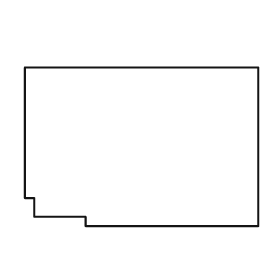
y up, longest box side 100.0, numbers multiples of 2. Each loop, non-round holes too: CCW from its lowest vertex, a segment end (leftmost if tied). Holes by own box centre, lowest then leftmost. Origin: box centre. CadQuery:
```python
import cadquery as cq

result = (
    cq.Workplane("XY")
    .moveTo(-24.0, -34.0)
    .lineTo(50.0, -34.0)
    .lineTo(50.0, 34.0)
    .lineTo(-50.0, 34.0)
    .lineTo(-50.0, -22.0)
    .lineTo(-46.0, -22.0)
    .lineTo(-46.0, -30.0)
    .lineTo(-24.0, -30.0)
    .close()
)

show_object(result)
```